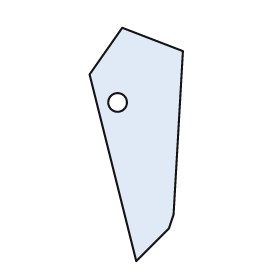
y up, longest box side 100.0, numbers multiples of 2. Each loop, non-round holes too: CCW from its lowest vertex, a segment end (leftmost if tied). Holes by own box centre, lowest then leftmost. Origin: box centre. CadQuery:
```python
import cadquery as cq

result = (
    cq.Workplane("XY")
    .moveTo(0.0, -50.0)
    .lineTo(14.0, -36.0)
    .lineTo(16.0, -30.0)
    .lineTo(20.0, 40.0)
    .lineTo(-6.0, 50.0)
    .lineTo(-20.0, 30.0)
    .close()
    .moveTo(-8.0, 18.0)
    .circle(4.0)
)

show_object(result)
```